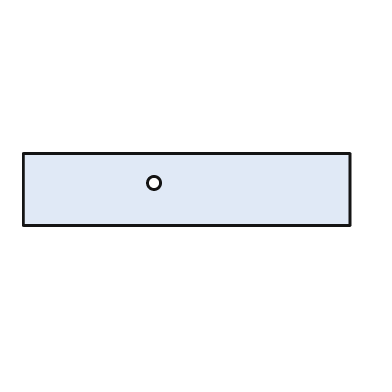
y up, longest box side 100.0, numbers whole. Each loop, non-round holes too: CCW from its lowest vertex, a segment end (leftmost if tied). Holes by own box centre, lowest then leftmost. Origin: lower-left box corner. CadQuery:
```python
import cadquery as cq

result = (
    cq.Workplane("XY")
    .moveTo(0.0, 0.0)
    .lineTo(100.0, 0.0)
    .lineTo(100.0, 22.0)
    .lineTo(0.0, 22.0)
    .close()
    .moveTo(40.0, 13.0)
    .circle(2.0)
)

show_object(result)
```